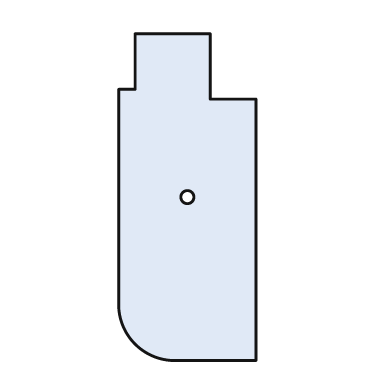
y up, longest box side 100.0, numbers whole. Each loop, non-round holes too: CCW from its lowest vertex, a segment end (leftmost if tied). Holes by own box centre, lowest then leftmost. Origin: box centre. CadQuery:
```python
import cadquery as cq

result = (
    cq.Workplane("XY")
    .moveTo(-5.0, -50.0)
    .lineTo(21.0, -50.0)
    .lineTo(21.0, 30.0)
    .lineTo(7.0, 30.0)
    .lineTo(7.0, 50.0)
    .lineTo(-16.0, 50.0)
    .lineTo(-16.0, 33.0)
    .lineTo(-21.0, 33.0)
    .lineTo(-21.0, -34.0)
    .threePointArc((-16.0, -45.0), (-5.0, -50.0))
    .close()
    .moveTo(0.0, 0.0)
    .circle(2.0)
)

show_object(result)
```